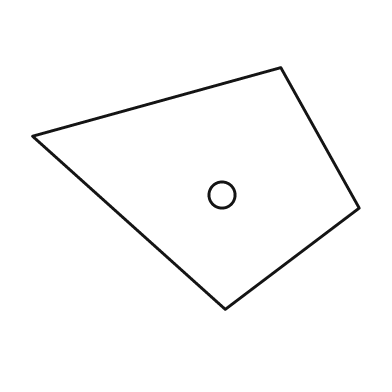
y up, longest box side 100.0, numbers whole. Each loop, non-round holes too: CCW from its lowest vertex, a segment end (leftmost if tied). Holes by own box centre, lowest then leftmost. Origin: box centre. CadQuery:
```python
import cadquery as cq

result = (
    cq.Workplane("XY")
    .moveTo(9.0, -37.0)
    .lineTo(50.0, -6.0)
    .lineTo(26.0, 37.0)
    .lineTo(-50.0, 16.0)
    .close()
    .moveTo(8.0, -2.0)
    .circle(4.0)
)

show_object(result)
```